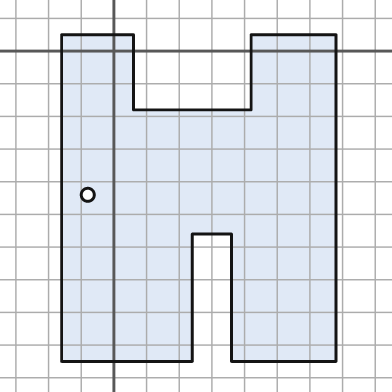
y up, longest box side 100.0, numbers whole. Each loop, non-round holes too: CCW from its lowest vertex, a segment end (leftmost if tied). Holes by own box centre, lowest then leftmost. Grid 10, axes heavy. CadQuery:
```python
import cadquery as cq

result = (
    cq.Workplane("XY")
    .moveTo(-16.0, -95.0)
    .lineTo(24.0, -95.0)
    .lineTo(24.0, -56.0)
    .lineTo(36.0, -56.0)
    .lineTo(36.0, -95.0)
    .lineTo(68.0, -95.0)
    .lineTo(68.0, 5.0)
    .lineTo(42.0, 5.0)
    .lineTo(42.0, -18.0)
    .lineTo(6.0, -18.0)
    .lineTo(6.0, 5.0)
    .lineTo(-16.0, 5.0)
    .close()
    .moveTo(-8.0, -44.0)
    .circle(2.0)
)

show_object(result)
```